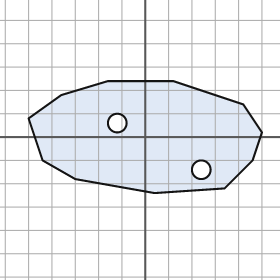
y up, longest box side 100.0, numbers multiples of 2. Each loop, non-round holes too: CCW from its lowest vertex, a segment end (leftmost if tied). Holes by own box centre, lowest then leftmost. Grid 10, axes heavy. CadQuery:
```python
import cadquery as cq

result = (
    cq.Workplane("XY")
    .moveTo(4.0, -24.0)
    .lineTo(34.0, -22.0)
    .lineTo(46.0, -10.0)
    .lineTo(50.0, 2.0)
    .lineTo(42.0, 14.0)
    .lineTo(12.0, 24.0)
    .lineTo(-16.0, 24.0)
    .lineTo(-36.0, 18.0)
    .lineTo(-50.0, 8.0)
    .lineTo(-44.0, -10.0)
    .lineTo(-30.0, -18.0)
    .close()
    .moveTo(24.0, -14.0)
    .circle(4.0)
    .moveTo(-12.0, 6.0)
    .circle(4.0)
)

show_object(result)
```